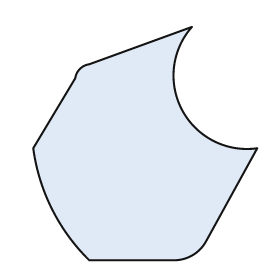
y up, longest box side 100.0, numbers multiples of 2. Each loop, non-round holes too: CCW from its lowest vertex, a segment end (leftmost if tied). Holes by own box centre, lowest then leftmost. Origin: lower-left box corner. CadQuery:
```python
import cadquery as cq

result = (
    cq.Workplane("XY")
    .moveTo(24.0, 0.0)
    .lineTo(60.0, 0.0)
    .threePointArc((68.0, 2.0), (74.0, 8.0))
    .lineTo(96.0, 48.0)
    .threePointArc((64.0, 64.0), (68.0, 100.0))
    .lineTo(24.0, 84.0)
    .threePointArc((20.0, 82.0), (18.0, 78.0))
    .lineTo(0.0, 48.0)
    .threePointArc((8.0, 22.0), (24.0, 0.0))
    .close()
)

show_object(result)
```